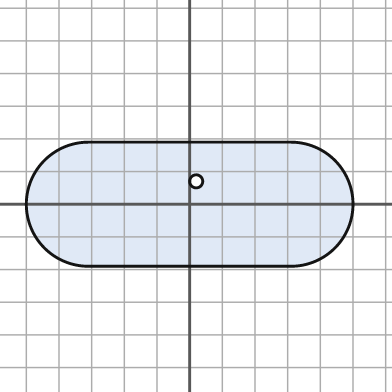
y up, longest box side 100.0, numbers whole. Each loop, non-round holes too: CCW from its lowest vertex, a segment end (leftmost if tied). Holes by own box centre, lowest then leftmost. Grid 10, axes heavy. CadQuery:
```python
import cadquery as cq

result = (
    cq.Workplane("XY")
    .moveTo(-31.0, -19.0)
    .lineTo(31.0, -19.0)
    .threePointArc((50.0, 0.0), (31.0, 19.0))
    .lineTo(-31.0, 19.0)
    .threePointArc((-50.0, 0.0), (-31.0, -19.0))
    .close()
    .moveTo(2.0, 7.0)
    .circle(2.0)
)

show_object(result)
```